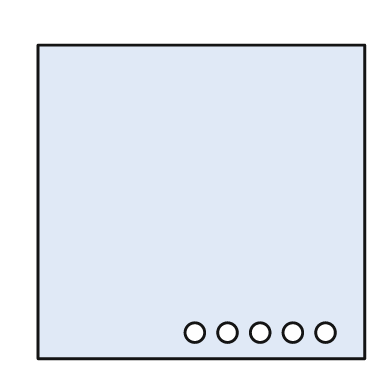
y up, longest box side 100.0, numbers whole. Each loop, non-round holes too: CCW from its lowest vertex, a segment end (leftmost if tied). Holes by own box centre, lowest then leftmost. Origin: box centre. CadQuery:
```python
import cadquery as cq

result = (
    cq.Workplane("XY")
    .moveTo(-50.0, -48.0)
    .lineTo(50.0, -48.0)
    .lineTo(50.0, 48.0)
    .lineTo(-50.0, 48.0)
    .close()
    .moveTo(-2.0, -40.0)
    .circle(3.0)
    .moveTo(8.0, -40.0)
    .circle(3.0)
    .moveTo(18.0, -40.0)
    .circle(3.0)
    .moveTo(28.0, -40.0)
    .circle(3.0)
    .moveTo(38.0, -40.0)
    .circle(3.0)
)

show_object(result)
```